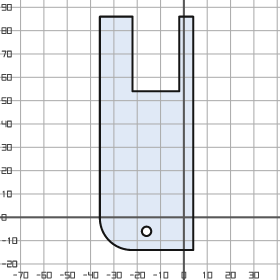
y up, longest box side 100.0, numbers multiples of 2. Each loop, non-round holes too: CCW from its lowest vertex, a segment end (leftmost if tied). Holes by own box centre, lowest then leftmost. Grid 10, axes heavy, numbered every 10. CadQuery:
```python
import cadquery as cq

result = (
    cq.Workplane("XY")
    .moveTo(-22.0, -14.0)
    .lineTo(4.0, -14.0)
    .lineTo(4.0, 86.0)
    .lineTo(-2.0, 86.0)
    .lineTo(-2.0, 54.0)
    .lineTo(-22.0, 54.0)
    .lineTo(-22.0, 86.0)
    .lineTo(-36.0, 86.0)
    .lineTo(-36.0, 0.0)
    .threePointArc((-32.0, -10.0), (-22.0, -14.0))
    .close()
    .moveTo(-16.0, -6.0)
    .circle(2.0)
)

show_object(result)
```